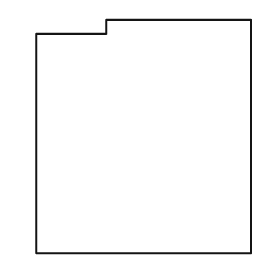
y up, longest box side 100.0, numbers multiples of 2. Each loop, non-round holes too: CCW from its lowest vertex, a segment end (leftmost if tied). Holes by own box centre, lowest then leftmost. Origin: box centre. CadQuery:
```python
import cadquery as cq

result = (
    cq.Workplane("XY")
    .moveTo(-46.0, -50.0)
    .lineTo(46.0, -50.0)
    .lineTo(46.0, 50.0)
    .lineTo(-16.0, 50.0)
    .lineTo(-16.0, 44.0)
    .lineTo(-46.0, 44.0)
    .close()
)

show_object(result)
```